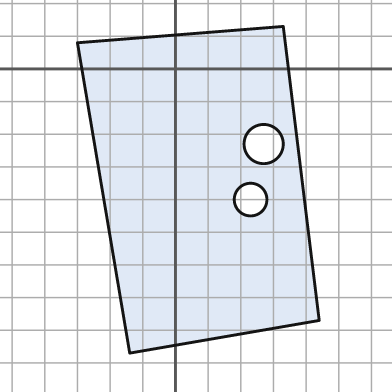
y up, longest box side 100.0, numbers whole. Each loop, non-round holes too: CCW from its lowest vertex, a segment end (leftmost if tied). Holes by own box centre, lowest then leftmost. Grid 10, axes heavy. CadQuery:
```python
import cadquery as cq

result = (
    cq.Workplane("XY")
    .moveTo(-14.0, -87.0)
    .lineTo(44.0, -77.0)
    .lineTo(33.0, 13.0)
    .lineTo(-30.0, 8.0)
    .close()
    .moveTo(23.0, -40.0)
    .circle(5.0)
    .moveTo(27.0, -23.0)
    .circle(6.0)
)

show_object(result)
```